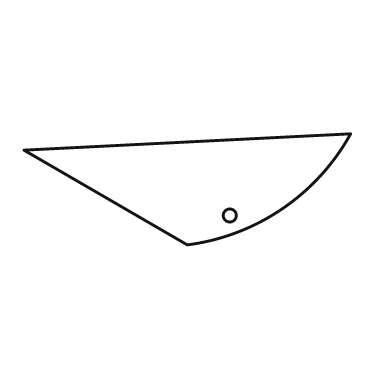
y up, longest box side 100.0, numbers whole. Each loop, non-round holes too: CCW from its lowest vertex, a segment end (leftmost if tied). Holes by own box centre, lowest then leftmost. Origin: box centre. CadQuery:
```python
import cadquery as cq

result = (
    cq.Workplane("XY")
    .moveTo(0.0, -17.0)
    .threePointArc((29.0, -6.0), (50.0, 17.0))
    .lineTo(-50.0, 12.0)
    .close()
    .moveTo(13.0, -8.0)
    .circle(2.0)
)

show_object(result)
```